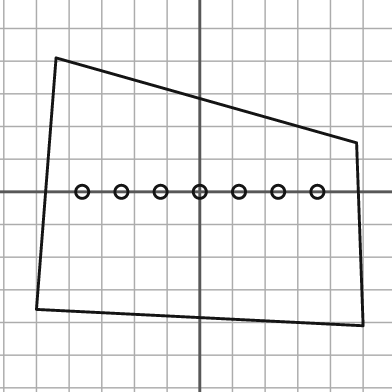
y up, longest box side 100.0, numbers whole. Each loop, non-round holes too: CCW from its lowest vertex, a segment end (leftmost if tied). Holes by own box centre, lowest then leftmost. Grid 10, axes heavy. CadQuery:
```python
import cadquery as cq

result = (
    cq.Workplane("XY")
    .moveTo(50.0, -41.0)
    .lineTo(48.0, 15.0)
    .lineTo(-44.0, 41.0)
    .lineTo(-50.0, -36.0)
    .close()
    .moveTo(-36.0, 0.0)
    .circle(2.0)
    .moveTo(-24.0, 0.0)
    .circle(2.0)
    .moveTo(-12.0, 0.0)
    .circle(2.0)
    .moveTo(0.0, 0.0)
    .circle(2.0)
    .moveTo(12.0, 0.0)
    .circle(2.0)
    .moveTo(24.0, 0.0)
    .circle(2.0)
    .moveTo(36.0, 0.0)
    .circle(2.0)
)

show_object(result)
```